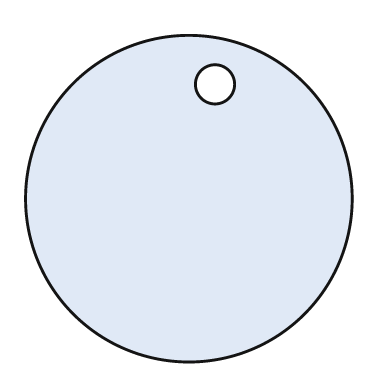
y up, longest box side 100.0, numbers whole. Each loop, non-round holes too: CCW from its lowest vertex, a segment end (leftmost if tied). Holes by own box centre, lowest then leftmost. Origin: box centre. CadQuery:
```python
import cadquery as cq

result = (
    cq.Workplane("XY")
    .moveTo(0.0, 0.0)
    .circle(50.0)
    .moveTo(8.0, 35.0)
    .circle(6.0)
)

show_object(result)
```